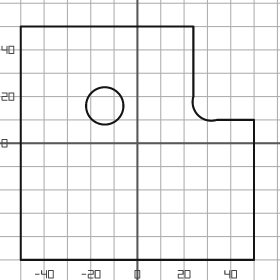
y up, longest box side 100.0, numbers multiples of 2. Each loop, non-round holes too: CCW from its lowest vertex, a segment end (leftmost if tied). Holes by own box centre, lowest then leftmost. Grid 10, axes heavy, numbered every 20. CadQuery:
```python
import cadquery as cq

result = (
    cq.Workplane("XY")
    .moveTo(-50.0, -50.0)
    .lineTo(50.0, -50.0)
    .lineTo(50.0, 10.0)
    .lineTo(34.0, 10.0)
    .threePointArc((26.0, 12.0), (24.0, 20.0))
    .lineTo(24.0, 50.0)
    .lineTo(-50.0, 50.0)
    .close()
    .moveTo(-14.0, 16.0)
    .circle(8.0)
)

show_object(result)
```